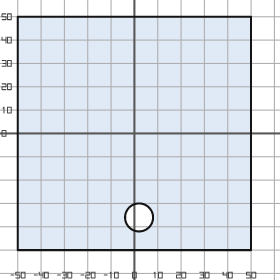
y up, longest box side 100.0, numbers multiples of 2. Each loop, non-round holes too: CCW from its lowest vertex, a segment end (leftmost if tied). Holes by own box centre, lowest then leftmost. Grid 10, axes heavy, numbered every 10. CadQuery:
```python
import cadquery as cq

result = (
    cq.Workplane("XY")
    .moveTo(-50.0, -50.0)
    .lineTo(50.0, -50.0)
    .lineTo(50.0, 50.0)
    .lineTo(-50.0, 50.0)
    .close()
    .moveTo(2.0, -36.0)
    .circle(6.0)
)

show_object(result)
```